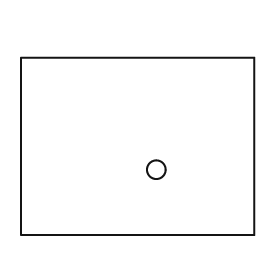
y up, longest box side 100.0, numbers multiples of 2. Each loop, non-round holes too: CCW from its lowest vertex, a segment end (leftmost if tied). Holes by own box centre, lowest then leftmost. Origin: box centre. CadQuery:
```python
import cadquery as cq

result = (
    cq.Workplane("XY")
    .moveTo(-50.0, -38.0)
    .lineTo(50.0, -38.0)
    .lineTo(50.0, 38.0)
    .lineTo(-50.0, 38.0)
    .close()
    .moveTo(8.0, -10.0)
    .circle(4.0)
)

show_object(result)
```